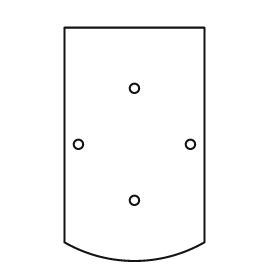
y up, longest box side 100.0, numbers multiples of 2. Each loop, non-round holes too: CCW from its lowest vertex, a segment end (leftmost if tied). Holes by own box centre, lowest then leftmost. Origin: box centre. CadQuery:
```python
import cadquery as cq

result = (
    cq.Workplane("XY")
    .moveTo(-30.0, -42.0)
    .threePointArc((0.0, -50.0), (30.0, -42.0))
    .lineTo(30.0, 50.0)
    .lineTo(-30.0, 50.0)
    .close()
    .moveTo(0.0, -24.0)
    .circle(2.0)
    .moveTo(-24.0, 0.0)
    .circle(2.0)
    .moveTo(24.0, 0.0)
    .circle(2.0)
    .moveTo(0.0, 24.0)
    .circle(2.0)
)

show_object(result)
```